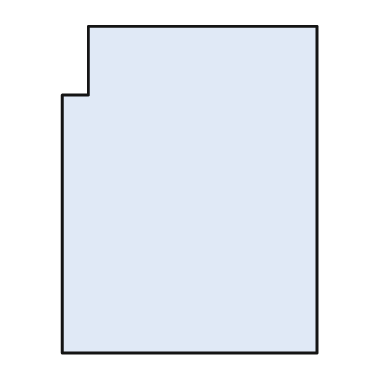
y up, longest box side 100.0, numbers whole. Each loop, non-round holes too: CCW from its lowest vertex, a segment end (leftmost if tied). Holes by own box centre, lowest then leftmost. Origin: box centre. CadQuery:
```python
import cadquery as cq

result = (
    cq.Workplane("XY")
    .moveTo(-39.0, -50.0)
    .lineTo(39.0, -50.0)
    .lineTo(39.0, 50.0)
    .lineTo(-31.0, 50.0)
    .lineTo(-31.0, 29.0)
    .lineTo(-39.0, 29.0)
    .close()
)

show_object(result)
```